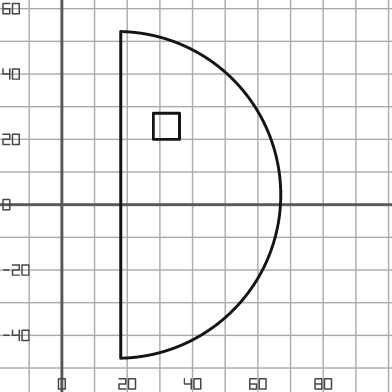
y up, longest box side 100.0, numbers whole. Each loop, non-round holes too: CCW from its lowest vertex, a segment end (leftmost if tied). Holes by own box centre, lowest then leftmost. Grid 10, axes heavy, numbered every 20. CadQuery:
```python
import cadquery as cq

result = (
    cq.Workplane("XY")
    .moveTo(18.0, -47.0)
    .threePointArc((67.0, 3.0), (18.0, 53.0))
    .close()
    .moveTo(28.0, 20.0)
    .lineTo(36.0, 20.0)
    .lineTo(36.0, 28.0)
    .lineTo(28.0, 28.0)
    .close()
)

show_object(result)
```